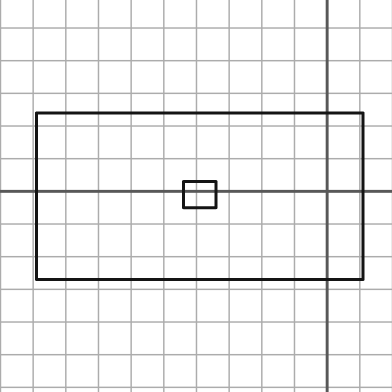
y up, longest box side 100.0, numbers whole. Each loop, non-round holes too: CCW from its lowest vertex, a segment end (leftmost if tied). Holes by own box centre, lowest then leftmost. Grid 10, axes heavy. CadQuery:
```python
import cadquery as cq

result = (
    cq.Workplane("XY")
    .moveTo(-89.0, -27.0)
    .lineTo(11.0, -27.0)
    .lineTo(11.0, 24.0)
    .lineTo(-89.0, 24.0)
    .close()
    .moveTo(-44.0, -5.0)
    .lineTo(-34.0, -5.0)
    .lineTo(-34.0, 3.0)
    .lineTo(-44.0, 3.0)
    .close()
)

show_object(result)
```